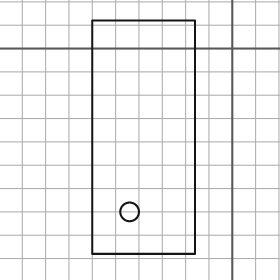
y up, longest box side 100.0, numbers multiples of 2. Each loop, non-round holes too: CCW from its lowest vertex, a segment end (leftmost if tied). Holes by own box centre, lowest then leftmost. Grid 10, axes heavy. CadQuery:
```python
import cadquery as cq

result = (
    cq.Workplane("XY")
    .moveTo(-60.0, -88.0)
    .lineTo(-16.0, -88.0)
    .lineTo(-16.0, 12.0)
    .lineTo(-60.0, 12.0)
    .close()
    .moveTo(-44.0, -70.0)
    .circle(4.0)
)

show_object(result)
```